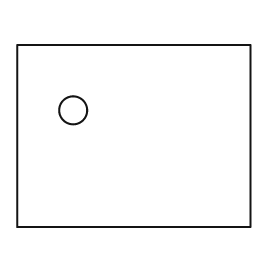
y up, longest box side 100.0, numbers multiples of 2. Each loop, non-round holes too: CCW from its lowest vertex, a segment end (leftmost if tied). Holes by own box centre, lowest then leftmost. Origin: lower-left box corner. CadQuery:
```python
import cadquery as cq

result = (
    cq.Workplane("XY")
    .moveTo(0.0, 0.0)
    .lineTo(100.0, 0.0)
    .lineTo(100.0, 78.0)
    .lineTo(0.0, 78.0)
    .close()
    .moveTo(24.0, 50.0)
    .circle(6.0)
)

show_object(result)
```